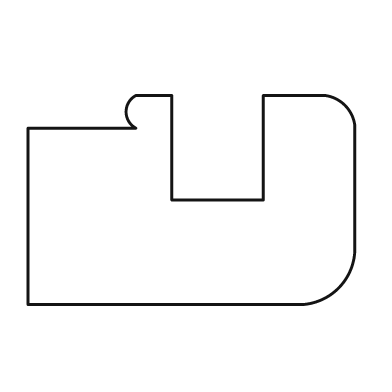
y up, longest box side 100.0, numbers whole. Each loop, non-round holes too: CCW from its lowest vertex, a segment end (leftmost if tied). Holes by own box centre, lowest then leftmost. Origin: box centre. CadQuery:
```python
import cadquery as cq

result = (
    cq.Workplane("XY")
    .moveTo(-50.0, -32.0)
    .lineTo(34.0, -32.0)
    .threePointArc((45.0, -27.0), (50.0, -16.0))
    .lineTo(50.0, 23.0)
    .threePointArc((47.0, 29.0), (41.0, 32.0))
    .lineTo(22.0, 32.0)
    .lineTo(22.0, 0.0)
    .lineTo(-6.0, 0.0)
    .lineTo(-6.0, 32.0)
    .lineTo(-17.0, 32.0)
    .threePointArc((-20.0, 27.0), (-17.0, 22.0))
    .lineTo(-50.0, 22.0)
    .close()
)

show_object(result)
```